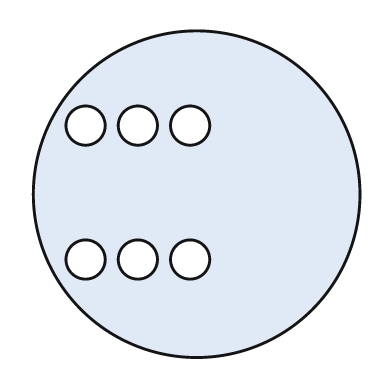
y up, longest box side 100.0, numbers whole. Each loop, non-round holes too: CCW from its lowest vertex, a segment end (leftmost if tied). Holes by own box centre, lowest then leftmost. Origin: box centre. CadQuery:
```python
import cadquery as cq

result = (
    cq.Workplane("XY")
    .moveTo(0.0, 0.0)
    .circle(50.0)
    .moveTo(-34.0, -20.0)
    .circle(6.0)
    .moveTo(-18.0, -20.0)
    .circle(6.0)
    .moveTo(-2.0, -20.0)
    .circle(6.0)
    .moveTo(-34.0, 21.0)
    .circle(6.0)
    .moveTo(-18.0, 21.0)
    .circle(6.0)
    .moveTo(-2.0, 21.0)
    .circle(6.0)
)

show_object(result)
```